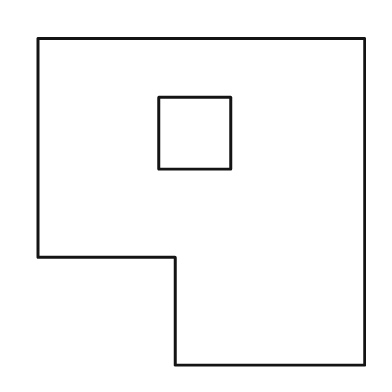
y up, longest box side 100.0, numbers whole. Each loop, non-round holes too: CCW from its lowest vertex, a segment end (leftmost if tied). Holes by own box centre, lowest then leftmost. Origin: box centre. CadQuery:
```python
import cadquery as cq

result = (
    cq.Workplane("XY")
    .moveTo(-8.0, -50.0)
    .lineTo(50.0, -50.0)
    .lineTo(50.0, 50.0)
    .lineTo(-50.0, 50.0)
    .lineTo(-50.0, -17.0)
    .lineTo(-8.0, -17.0)
    .close()
    .moveTo(-13.0, 10.0)
    .lineTo(9.0, 10.0)
    .lineTo(9.0, 32.0)
    .lineTo(-13.0, 32.0)
    .close()
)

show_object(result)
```